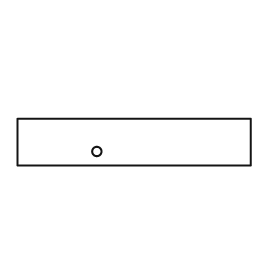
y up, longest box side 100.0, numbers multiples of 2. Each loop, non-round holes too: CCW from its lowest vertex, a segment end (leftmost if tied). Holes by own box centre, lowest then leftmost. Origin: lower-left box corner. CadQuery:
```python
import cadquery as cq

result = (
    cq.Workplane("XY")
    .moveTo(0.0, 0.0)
    .lineTo(100.0, 0.0)
    .lineTo(100.0, 20.0)
    .lineTo(0.0, 20.0)
    .close()
    .moveTo(34.0, 6.0)
    .circle(2.0)
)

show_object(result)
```